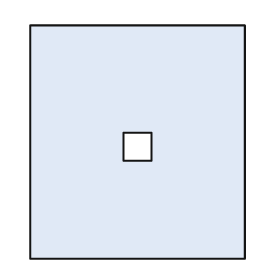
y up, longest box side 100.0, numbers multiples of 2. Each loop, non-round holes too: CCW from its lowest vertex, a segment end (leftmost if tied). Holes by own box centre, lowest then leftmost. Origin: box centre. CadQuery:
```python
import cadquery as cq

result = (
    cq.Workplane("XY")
    .moveTo(-46.0, -50.0)
    .lineTo(46.0, -50.0)
    .lineTo(46.0, 50.0)
    .lineTo(-46.0, 50.0)
    .close()
    .moveTo(-6.0, -8.0)
    .lineTo(6.0, -8.0)
    .lineTo(6.0, 4.0)
    .lineTo(-6.0, 4.0)
    .close()
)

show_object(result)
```